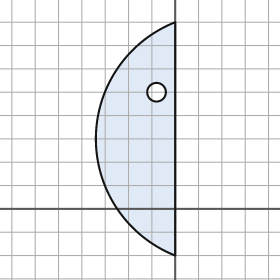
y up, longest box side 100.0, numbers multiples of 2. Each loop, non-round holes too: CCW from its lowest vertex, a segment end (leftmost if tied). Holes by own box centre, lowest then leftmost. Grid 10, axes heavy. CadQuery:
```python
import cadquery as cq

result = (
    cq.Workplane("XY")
    .moveTo(0.0, -20.0)
    .lineTo(0.0, 80.0)
    .threePointArc((-34.0, 30.0), (0.0, -20.0))
    .close()
    .moveTo(-8.0, 50.0)
    .circle(4.0)
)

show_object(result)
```